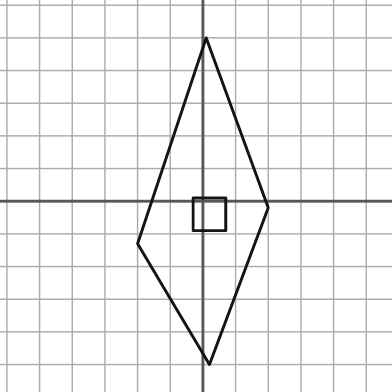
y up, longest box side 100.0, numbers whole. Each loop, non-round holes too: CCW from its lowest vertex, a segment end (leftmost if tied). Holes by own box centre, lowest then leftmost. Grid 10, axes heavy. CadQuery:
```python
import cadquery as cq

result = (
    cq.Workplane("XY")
    .moveTo(2.0, -50.0)
    .lineTo(20.0, -2.0)
    .lineTo(1.0, 50.0)
    .lineTo(-20.0, -13.0)
    .close()
    .moveTo(-3.0, -9.0)
    .lineTo(7.0, -9.0)
    .lineTo(7.0, 1.0)
    .lineTo(-3.0, 1.0)
    .close()
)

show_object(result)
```